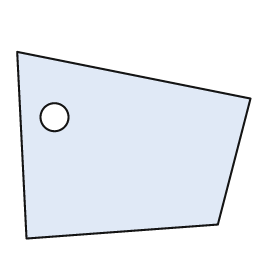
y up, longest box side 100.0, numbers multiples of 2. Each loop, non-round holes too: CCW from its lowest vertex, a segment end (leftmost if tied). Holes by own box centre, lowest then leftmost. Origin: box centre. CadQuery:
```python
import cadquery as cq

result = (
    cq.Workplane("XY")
    .moveTo(-46.0, -40.0)
    .lineTo(36.0, -34.0)
    .lineTo(50.0, 20.0)
    .lineTo(-50.0, 40.0)
    .close()
    .moveTo(-34.0, 12.0)
    .circle(6.0)
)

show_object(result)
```